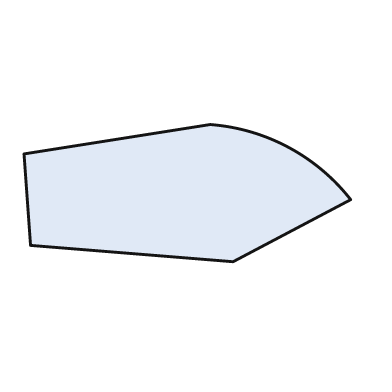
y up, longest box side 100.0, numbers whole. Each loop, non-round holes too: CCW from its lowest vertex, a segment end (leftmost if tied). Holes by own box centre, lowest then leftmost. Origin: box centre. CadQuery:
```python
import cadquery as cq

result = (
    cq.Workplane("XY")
    .moveTo(14.0, -21.0)
    .lineTo(50.0, -2.0)
    .threePointArc((31.0, 14.0), (7.0, 21.0))
    .lineTo(-50.0, 12.0)
    .lineTo(-48.0, -16.0)
    .close()
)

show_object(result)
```